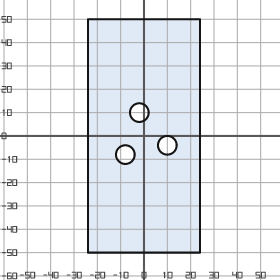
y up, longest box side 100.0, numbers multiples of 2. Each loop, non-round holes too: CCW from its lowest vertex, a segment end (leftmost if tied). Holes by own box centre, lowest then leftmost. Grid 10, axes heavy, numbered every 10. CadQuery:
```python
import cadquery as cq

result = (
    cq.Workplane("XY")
    .moveTo(-24.0, -50.0)
    .lineTo(24.0, -50.0)
    .lineTo(24.0, 50.0)
    .lineTo(-24.0, 50.0)
    .close()
    .moveTo(-8.0, -8.0)
    .circle(4.0)
    .moveTo(10.0, -4.0)
    .circle(4.0)
    .moveTo(-2.0, 10.0)
    .circle(4.0)
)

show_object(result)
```